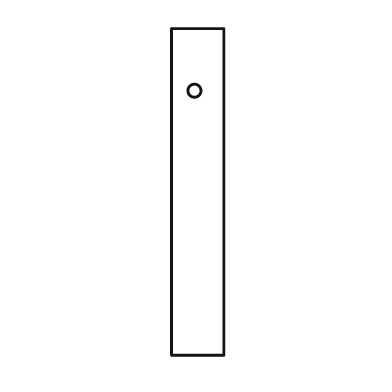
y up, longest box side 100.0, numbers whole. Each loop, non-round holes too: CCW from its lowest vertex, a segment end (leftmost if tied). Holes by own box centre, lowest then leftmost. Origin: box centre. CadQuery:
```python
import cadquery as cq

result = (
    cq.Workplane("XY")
    .moveTo(-8.0, -50.0)
    .lineTo(8.0, -50.0)
    .lineTo(8.0, 50.0)
    .lineTo(-8.0, 50.0)
    .close()
    .moveTo(-1.0, 31.0)
    .circle(2.0)
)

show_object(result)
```